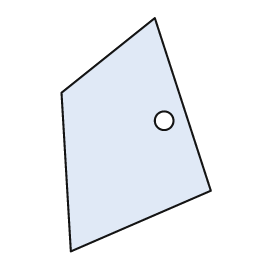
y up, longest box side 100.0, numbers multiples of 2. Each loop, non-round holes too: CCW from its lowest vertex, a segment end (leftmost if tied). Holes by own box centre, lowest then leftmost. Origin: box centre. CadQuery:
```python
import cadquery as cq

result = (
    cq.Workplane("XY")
    .moveTo(-28.0, -50.0)
    .lineTo(32.0, -24.0)
    .lineTo(8.0, 50.0)
    .lineTo(-32.0, 18.0)
    .close()
    .moveTo(12.0, 6.0)
    .circle(4.0)
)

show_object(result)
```